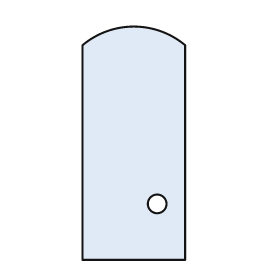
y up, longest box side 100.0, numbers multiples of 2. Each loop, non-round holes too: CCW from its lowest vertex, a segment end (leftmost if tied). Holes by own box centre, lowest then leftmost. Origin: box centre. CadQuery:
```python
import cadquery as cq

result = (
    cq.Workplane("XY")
    .moveTo(-22.0, -50.0)
    .lineTo(22.0, -50.0)
    .lineTo(22.0, 42.0)
    .threePointArc((0.0, 50.0), (-22.0, 42.0))
    .close()
    .moveTo(10.0, -26.0)
    .circle(4.0)
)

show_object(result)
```